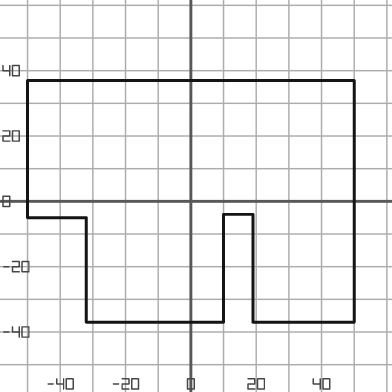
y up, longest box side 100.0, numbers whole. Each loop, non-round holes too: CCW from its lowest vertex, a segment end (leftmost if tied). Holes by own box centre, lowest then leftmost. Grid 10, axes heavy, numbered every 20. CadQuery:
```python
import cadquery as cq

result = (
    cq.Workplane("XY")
    .moveTo(-32.0, -37.0)
    .lineTo(10.0, -37.0)
    .lineTo(10.0, -4.0)
    .lineTo(19.0, -4.0)
    .lineTo(19.0, -37.0)
    .lineTo(50.0, -37.0)
    .lineTo(50.0, 37.0)
    .lineTo(-50.0, 37.0)
    .lineTo(-50.0, -5.0)
    .lineTo(-32.0, -5.0)
    .close()
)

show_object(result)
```